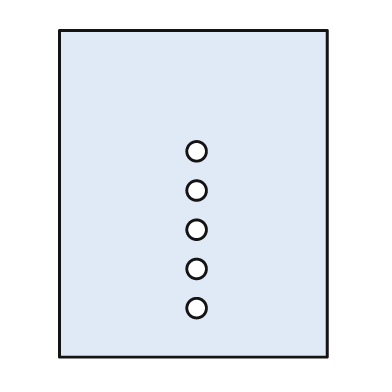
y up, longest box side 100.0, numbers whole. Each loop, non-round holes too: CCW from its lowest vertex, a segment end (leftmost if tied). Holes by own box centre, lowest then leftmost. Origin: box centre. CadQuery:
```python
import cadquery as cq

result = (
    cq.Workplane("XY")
    .moveTo(-41.0, -50.0)
    .lineTo(41.0, -50.0)
    .lineTo(41.0, 50.0)
    .lineTo(-41.0, 50.0)
    .close()
    .moveTo(1.0, -35.0)
    .circle(3.0)
    .moveTo(1.0, -23.0)
    .circle(3.0)
    .moveTo(1.0, -11.0)
    .circle(3.0)
    .moveTo(1.0, 1.0)
    .circle(3.0)
    .moveTo(1.0, 13.0)
    .circle(3.0)
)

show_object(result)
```